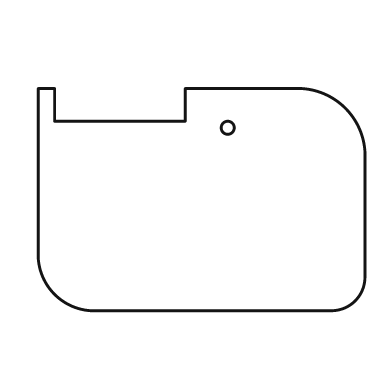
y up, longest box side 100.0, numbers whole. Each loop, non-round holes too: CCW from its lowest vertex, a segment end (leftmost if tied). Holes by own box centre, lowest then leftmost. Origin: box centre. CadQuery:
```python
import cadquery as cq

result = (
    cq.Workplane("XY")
    .moveTo(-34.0, -34.0)
    .lineTo(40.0, -34.0)
    .threePointArc((47.0, -31.0), (50.0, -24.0))
    .lineTo(50.0, 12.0)
    .threePointArc((44.0, 28.0), (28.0, 34.0))
    .lineTo(-5.0, 34.0)
    .lineTo(-5.0, 24.0)
    .lineTo(-45.0, 24.0)
    .lineTo(-45.0, 34.0)
    .lineTo(-50.0, 34.0)
    .lineTo(-50.0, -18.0)
    .threePointArc((-45.0, -29.0), (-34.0, -34.0))
    .close()
    .moveTo(8.0, 22.0)
    .circle(2.0)
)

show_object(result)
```